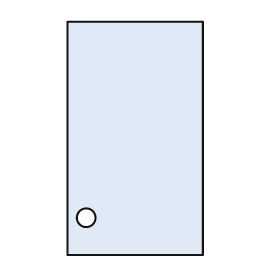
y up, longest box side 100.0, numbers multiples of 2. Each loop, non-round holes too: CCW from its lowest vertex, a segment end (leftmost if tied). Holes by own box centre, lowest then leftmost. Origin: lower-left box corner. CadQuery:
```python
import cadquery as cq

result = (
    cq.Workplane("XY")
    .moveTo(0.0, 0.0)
    .lineTo(58.0, 0.0)
    .lineTo(58.0, 100.0)
    .lineTo(0.0, 100.0)
    .close()
    .moveTo(8.0, 16.0)
    .circle(4.0)
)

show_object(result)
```